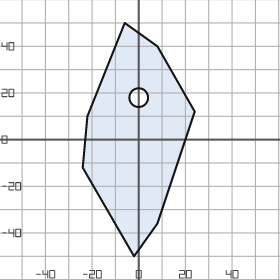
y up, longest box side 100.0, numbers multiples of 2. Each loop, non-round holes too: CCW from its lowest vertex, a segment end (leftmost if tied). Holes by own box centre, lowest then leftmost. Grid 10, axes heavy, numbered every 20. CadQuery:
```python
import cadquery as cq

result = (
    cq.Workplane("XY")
    .moveTo(-2.0, -50.0)
    .lineTo(8.0, -36.0)
    .lineTo(24.0, 12.0)
    .lineTo(8.0, 40.0)
    .lineTo(-6.0, 50.0)
    .lineTo(-22.0, 10.0)
    .lineTo(-24.0, -12.0)
    .close()
    .moveTo(0.0, 18.0)
    .circle(4.0)
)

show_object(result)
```